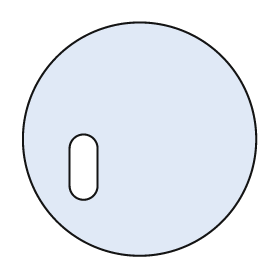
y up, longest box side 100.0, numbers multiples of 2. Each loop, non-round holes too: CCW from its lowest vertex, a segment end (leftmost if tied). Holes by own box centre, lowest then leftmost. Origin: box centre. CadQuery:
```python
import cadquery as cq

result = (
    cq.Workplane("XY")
    .moveTo(0.0, 0.0)
    .circle(50.0)
    .moveTo(-30.0, -20.0)
    .threePointArc((-24.0, -26.0), (-18.0, -20.0))
    .lineTo(-18.0, -4.0)
    .threePointArc((-24.0, 2.0), (-30.0, -4.0))
    .close()
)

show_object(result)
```